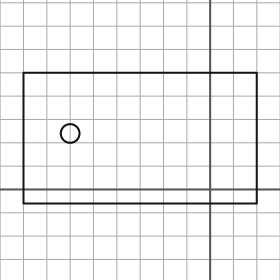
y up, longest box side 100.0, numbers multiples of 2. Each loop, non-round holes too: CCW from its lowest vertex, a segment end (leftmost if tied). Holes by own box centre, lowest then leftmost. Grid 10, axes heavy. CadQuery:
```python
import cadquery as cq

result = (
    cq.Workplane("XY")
    .moveTo(-80.0, -6.0)
    .lineTo(20.0, -6.0)
    .lineTo(20.0, 50.0)
    .lineTo(-80.0, 50.0)
    .close()
    .moveTo(-60.0, 24.0)
    .circle(4.0)
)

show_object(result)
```